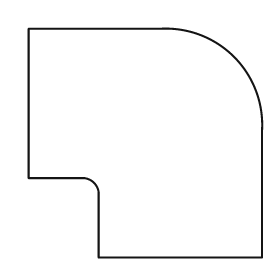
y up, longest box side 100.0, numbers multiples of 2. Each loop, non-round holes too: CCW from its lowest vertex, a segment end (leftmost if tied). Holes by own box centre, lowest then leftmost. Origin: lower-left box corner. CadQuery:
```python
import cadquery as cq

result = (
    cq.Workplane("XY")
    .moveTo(30.0, 0.0)
    .lineTo(100.0, 0.0)
    .lineTo(100.0, 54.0)
    .threePointArc((88.0, 86.0), (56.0, 98.0))
    .lineTo(0.0, 98.0)
    .lineTo(0.0, 34.0)
    .lineTo(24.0, 34.0)
    .threePointArc((28.0, 32.0), (30.0, 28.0))
    .close()
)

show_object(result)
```